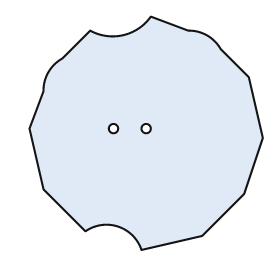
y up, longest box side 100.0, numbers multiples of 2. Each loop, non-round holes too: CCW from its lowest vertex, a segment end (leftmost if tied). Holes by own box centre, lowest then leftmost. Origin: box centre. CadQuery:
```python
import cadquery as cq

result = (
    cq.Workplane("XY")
    .moveTo(-2.0, -50.0)
    .lineTo(24.0, -44.0)
    .lineTo(42.0, -26.0)
    .lineTo(50.0, -2.0)
    .lineTo(44.0, 24.0)
    .lineTo(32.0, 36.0)
    .threePointArc((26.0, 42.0), (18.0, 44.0))
    .lineTo(2.0, 50.0)
    .threePointArc((-10.0, 42.0), (-24.0, 44.0))
    .lineTo(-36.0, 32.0)
    .threePointArc((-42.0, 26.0), (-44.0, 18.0))
    .lineTo(-50.0, 2.0)
    .lineTo(-44.0, -24.0)
    .lineTo(-26.0, -42.0)
    .threePointArc((-12.0, -40.0), (-2.0, -50.0))
    .close()
    .moveTo(-14.0, 2.0)
    .circle(2.0)
    .moveTo(0.0, 2.0)
    .circle(2.0)
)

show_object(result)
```